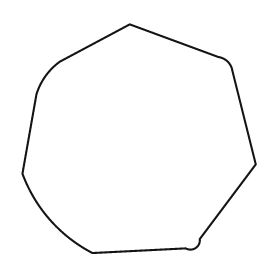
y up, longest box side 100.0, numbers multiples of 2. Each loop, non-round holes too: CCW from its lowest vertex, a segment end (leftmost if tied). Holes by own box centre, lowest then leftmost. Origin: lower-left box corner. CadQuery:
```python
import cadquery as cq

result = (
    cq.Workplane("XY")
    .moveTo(30.0, 0.0)
    .lineTo(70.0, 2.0)
    .threePointArc((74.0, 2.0), (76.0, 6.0))
    .lineTo(100.0, 38.0)
    .lineTo(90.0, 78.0)
    .threePointArc((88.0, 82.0), (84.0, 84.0))
    .lineTo(46.0, 98.0)
    .lineTo(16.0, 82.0)
    .threePointArc((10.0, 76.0), (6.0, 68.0))
    .lineTo(0.0, 34.0)
    .threePointArc((12.0, 14.0), (30.0, 0.0))
    .close()
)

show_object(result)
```